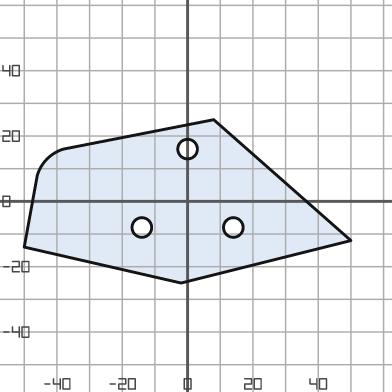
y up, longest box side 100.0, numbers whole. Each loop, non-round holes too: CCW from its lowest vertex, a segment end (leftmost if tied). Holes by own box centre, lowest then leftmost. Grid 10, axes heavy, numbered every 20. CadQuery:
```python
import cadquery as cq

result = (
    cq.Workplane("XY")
    .moveTo(-2.0, -25.0)
    .lineTo(50.0, -12.0)
    .lineTo(8.0, 25.0)
    .lineTo(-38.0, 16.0)
    .threePointArc((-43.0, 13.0), (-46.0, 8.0))
    .lineTo(-50.0, -14.0)
    .close()
    .moveTo(-14.0, -8.0)
    .circle(3.0)
    .moveTo(14.0, -8.0)
    .circle(3.0)
    .moveTo(0.0, 16.0)
    .circle(3.0)
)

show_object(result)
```